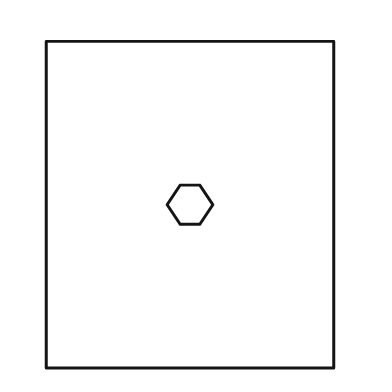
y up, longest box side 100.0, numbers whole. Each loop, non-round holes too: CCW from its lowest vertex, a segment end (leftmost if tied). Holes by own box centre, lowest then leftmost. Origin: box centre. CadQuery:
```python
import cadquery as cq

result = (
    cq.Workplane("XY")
    .moveTo(-44.0, -50.0)
    .lineTo(44.0, -50.0)
    .lineTo(44.0, 50.0)
    .lineTo(-44.0, 50.0)
    .close()
    .moveTo(-3.0, -6.0)
    .lineTo(3.0, -6.0)
    .lineTo(7.0, 0.0)
    .lineTo(3.0, 6.0)
    .lineTo(-3.0, 6.0)
    .lineTo(-7.0, 0.0)
    .close()
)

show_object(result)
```